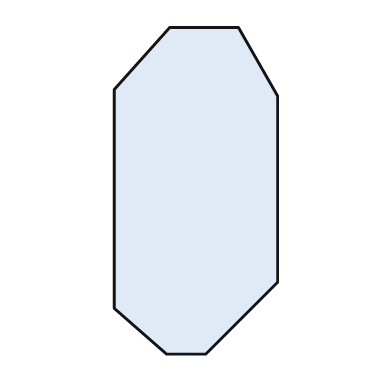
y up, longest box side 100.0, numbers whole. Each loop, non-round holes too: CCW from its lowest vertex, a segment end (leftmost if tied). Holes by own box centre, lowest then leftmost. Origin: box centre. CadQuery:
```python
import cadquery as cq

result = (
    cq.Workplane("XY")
    .moveTo(-9.0, -50.0)
    .lineTo(3.0, -50.0)
    .lineTo(25.0, -28.0)
    .lineTo(25.0, 29.0)
    .lineTo(13.0, 50.0)
    .lineTo(-8.0, 50.0)
    .lineTo(-25.0, 31.0)
    .lineTo(-25.0, -36.0)
    .close()
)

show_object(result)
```